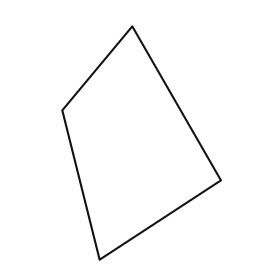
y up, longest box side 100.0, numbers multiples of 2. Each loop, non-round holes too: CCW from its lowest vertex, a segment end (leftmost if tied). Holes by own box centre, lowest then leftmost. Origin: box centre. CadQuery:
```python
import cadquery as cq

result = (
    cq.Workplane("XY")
    .moveTo(-18.0, -50.0)
    .lineTo(34.0, -16.0)
    .lineTo(-4.0, 50.0)
    .lineTo(-34.0, 14.0)
    .close()
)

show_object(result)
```